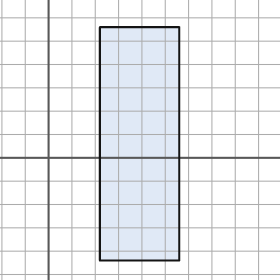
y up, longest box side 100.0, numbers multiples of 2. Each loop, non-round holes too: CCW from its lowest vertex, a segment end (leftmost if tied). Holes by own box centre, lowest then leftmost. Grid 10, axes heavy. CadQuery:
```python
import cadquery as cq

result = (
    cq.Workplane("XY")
    .moveTo(22.0, -44.0)
    .lineTo(56.0, -44.0)
    .lineTo(56.0, 56.0)
    .lineTo(22.0, 56.0)
    .close()
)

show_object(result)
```